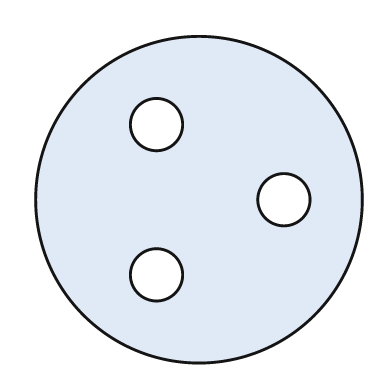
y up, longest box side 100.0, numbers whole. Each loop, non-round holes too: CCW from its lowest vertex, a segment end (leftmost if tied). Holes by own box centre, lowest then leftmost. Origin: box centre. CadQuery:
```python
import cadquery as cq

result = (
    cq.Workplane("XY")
    .moveTo(0.0, 0.0)
    .circle(50.0)
    .moveTo(-13.0, -23.0)
    .circle(8.0)
    .moveTo(26.0, 0.0)
    .circle(8.0)
    .moveTo(-13.0, 23.0)
    .circle(8.0)
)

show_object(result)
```